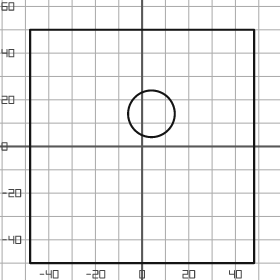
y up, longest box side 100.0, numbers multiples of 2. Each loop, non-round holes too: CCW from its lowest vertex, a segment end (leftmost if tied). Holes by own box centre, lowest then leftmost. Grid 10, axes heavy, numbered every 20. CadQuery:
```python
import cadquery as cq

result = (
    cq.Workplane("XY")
    .moveTo(-48.0, -50.0)
    .lineTo(48.0, -50.0)
    .lineTo(48.0, 50.0)
    .lineTo(-48.0, 50.0)
    .close()
    .moveTo(4.0, 14.0)
    .circle(10.0)
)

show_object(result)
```